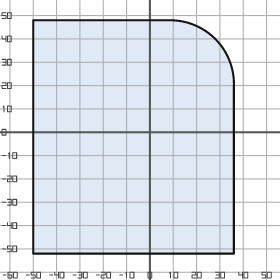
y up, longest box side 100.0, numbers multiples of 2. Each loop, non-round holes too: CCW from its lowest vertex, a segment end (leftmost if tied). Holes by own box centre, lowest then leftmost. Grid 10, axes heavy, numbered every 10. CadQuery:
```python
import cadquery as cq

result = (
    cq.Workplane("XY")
    .moveTo(-50.0, -52.0)
    .lineTo(36.0, -52.0)
    .lineTo(36.0, 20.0)
    .threePointArc((28.0, 40.0), (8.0, 48.0))
    .lineTo(-50.0, 48.0)
    .close()
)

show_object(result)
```